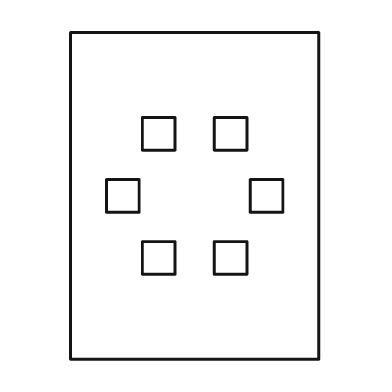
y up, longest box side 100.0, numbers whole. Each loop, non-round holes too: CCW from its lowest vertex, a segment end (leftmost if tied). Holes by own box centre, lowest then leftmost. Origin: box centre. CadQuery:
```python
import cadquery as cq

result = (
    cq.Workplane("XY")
    .moveTo(-38.0, -50.0)
    .lineTo(38.0, -50.0)
    .lineTo(38.0, 50.0)
    .lineTo(-38.0, 50.0)
    .close()
    .moveTo(-16.0, -24.0)
    .lineTo(-6.0, -24.0)
    .lineTo(-6.0, -14.0)
    .lineTo(-16.0, -14.0)
    .close()
    .moveTo(6.0, -24.0)
    .lineTo(16.0, -24.0)
    .lineTo(16.0, -14.0)
    .lineTo(6.0, -14.0)
    .close()
    .moveTo(-27.0, -5.0)
    .lineTo(-17.0, -5.0)
    .lineTo(-17.0, 5.0)
    .lineTo(-27.0, 5.0)
    .close()
    .moveTo(17.0, -5.0)
    .lineTo(27.0, -5.0)
    .lineTo(27.0, 5.0)
    .lineTo(17.0, 5.0)
    .close()
    .moveTo(-16.0, 14.0)
    .lineTo(-6.0, 14.0)
    .lineTo(-6.0, 24.0)
    .lineTo(-16.0, 24.0)
    .close()
    .moveTo(6.0, 14.0)
    .lineTo(16.0, 14.0)
    .lineTo(16.0, 24.0)
    .lineTo(6.0, 24.0)
    .close()
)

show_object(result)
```